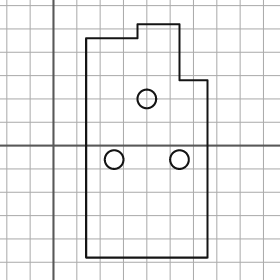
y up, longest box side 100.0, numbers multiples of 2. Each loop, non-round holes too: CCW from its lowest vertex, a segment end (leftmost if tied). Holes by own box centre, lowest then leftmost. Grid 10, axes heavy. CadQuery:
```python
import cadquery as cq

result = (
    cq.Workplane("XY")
    .moveTo(14.0, -48.0)
    .lineTo(66.0, -48.0)
    .lineTo(66.0, 28.0)
    .lineTo(54.0, 28.0)
    .lineTo(54.0, 52.0)
    .lineTo(36.0, 52.0)
    .lineTo(36.0, 46.0)
    .lineTo(14.0, 46.0)
    .close()
    .moveTo(26.0, -6.0)
    .circle(4.0)
    .moveTo(54.0, -6.0)
    .circle(4.0)
    .moveTo(40.0, 20.0)
    .circle(4.0)
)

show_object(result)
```